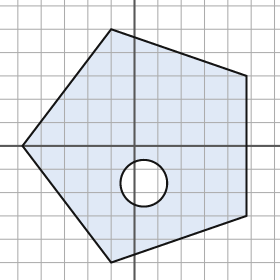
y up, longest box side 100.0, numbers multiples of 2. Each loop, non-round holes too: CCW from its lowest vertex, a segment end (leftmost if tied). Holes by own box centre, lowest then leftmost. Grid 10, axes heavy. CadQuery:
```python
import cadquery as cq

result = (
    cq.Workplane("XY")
    .moveTo(-10.0, -50.0)
    .lineTo(48.0, -30.0)
    .lineTo(48.0, 30.0)
    .lineTo(-10.0, 50.0)
    .lineTo(-48.0, 0.0)
    .close()
    .moveTo(4.0, -16.0)
    .circle(10.0)
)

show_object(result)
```